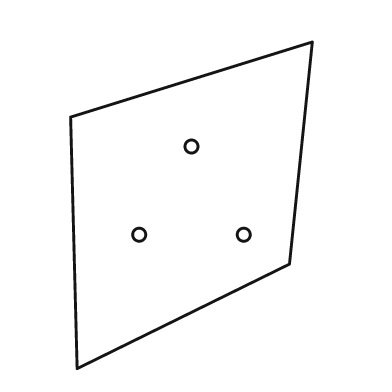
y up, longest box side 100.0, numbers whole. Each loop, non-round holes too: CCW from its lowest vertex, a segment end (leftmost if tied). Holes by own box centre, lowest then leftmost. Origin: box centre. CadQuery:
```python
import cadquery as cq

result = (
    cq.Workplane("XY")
    .moveTo(-35.0, -50.0)
    .lineTo(30.0, -18.0)
    .lineTo(37.0, 50.0)
    .lineTo(-37.0, 27.0)
    .close()
    .moveTo(-16.0, -9.0)
    .circle(2.0)
    .moveTo(16.0, -9.0)
    .circle(2.0)
    .moveTo(0.0, 18.0)
    .circle(2.0)
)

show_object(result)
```